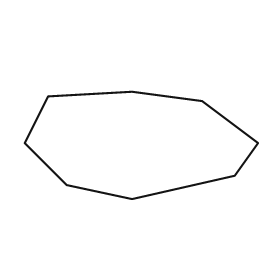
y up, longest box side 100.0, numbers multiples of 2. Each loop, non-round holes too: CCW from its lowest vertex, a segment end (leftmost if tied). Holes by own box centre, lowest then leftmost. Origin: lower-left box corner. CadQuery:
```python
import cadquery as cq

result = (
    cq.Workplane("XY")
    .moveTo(46.0, 0.0)
    .lineTo(90.0, 10.0)
    .lineTo(100.0, 24.0)
    .lineTo(76.0, 42.0)
    .lineTo(46.0, 46.0)
    .lineTo(10.0, 44.0)
    .lineTo(0.0, 24.0)
    .lineTo(18.0, 6.0)
    .close()
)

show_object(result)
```